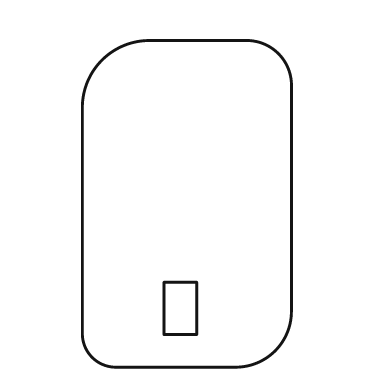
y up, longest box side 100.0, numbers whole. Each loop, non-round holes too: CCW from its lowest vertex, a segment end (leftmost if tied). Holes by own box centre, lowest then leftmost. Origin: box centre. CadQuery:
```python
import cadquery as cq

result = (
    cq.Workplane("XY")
    .moveTo(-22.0, -50.0)
    .lineTo(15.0, -50.0)
    .threePointArc((27.0, -45.0), (32.0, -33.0))
    .lineTo(32.0, 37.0)
    .threePointArc((28.0, 46.0), (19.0, 50.0))
    .lineTo(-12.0, 50.0)
    .threePointArc((-26.0, 44.0), (-32.0, 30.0))
    .lineTo(-32.0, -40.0)
    .threePointArc((-29.0, -47.0), (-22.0, -50.0))
    .close()
    .moveTo(-7.0, -40.0)
    .lineTo(3.0, -40.0)
    .lineTo(3.0, -24.0)
    .lineTo(-7.0, -24.0)
    .close()
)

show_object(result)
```